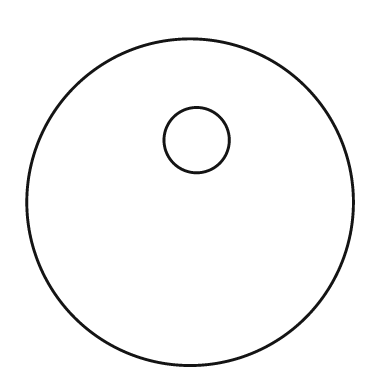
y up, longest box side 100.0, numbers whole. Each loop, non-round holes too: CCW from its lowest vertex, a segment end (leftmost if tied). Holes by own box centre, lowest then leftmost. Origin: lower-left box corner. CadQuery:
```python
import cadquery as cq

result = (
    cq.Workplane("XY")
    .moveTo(50.0, 50.0)
    .circle(50.0)
    .moveTo(52.0, 69.0)
    .circle(10.0)
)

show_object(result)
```